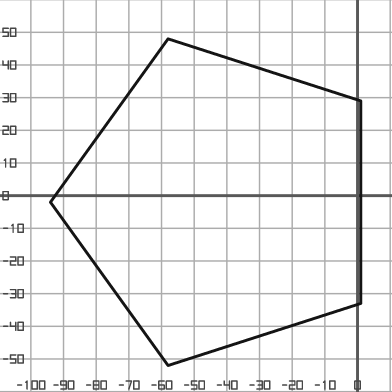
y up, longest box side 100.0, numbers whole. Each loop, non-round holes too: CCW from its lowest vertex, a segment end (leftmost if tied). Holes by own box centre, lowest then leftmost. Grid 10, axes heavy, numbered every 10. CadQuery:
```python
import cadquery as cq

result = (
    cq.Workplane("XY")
    .moveTo(-58.0, -52.0)
    .lineTo(1.0, -33.0)
    .lineTo(1.0, 29.0)
    .lineTo(-58.0, 48.0)
    .lineTo(-94.0, -2.0)
    .close()
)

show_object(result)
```